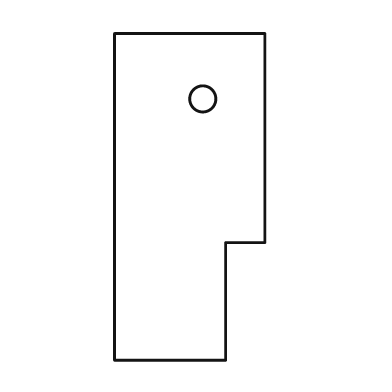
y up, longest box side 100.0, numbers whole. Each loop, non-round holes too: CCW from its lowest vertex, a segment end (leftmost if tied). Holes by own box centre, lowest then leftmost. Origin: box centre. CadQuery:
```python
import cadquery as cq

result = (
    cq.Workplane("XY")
    .moveTo(-23.0, -50.0)
    .lineTo(11.0, -50.0)
    .lineTo(11.0, -14.0)
    .lineTo(23.0, -14.0)
    .lineTo(23.0, 50.0)
    .lineTo(-23.0, 50.0)
    .close()
    .moveTo(4.0, 30.0)
    .circle(4.0)
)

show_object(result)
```